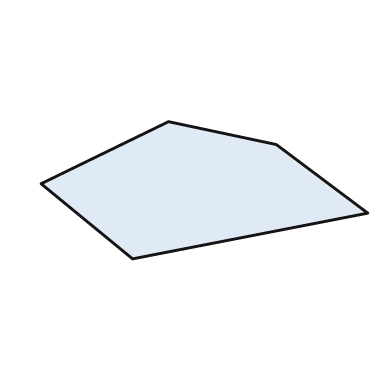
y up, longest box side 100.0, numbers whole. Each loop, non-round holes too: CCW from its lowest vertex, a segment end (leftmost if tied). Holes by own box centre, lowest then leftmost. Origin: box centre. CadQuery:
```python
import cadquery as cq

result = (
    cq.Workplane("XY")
    .moveTo(-22.0, -21.0)
    .lineTo(50.0, -7.0)
    .lineTo(22.0, 14.0)
    .lineTo(-11.0, 21.0)
    .lineTo(-50.0, 2.0)
    .close()
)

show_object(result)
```